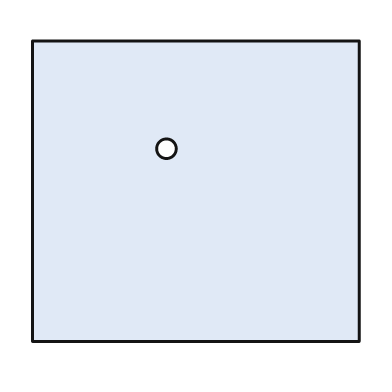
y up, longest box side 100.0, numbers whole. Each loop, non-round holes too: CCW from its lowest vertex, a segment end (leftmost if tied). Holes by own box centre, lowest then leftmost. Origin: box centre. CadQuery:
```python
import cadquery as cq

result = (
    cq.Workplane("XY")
    .moveTo(-50.0, -46.0)
    .lineTo(50.0, -46.0)
    .lineTo(50.0, 46.0)
    .lineTo(-50.0, 46.0)
    .close()
    .moveTo(-9.0, 13.0)
    .circle(3.0)
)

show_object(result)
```